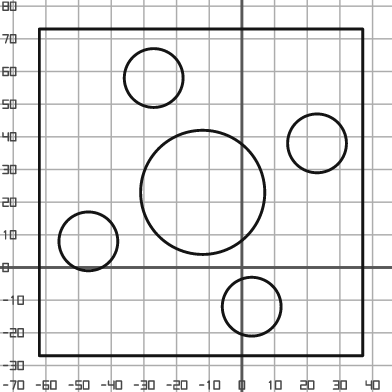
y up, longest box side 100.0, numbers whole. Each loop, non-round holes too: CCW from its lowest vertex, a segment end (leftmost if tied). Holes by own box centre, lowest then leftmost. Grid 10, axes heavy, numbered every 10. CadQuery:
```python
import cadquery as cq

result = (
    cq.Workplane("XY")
    .moveTo(-62.0, -27.0)
    .lineTo(37.0, -27.0)
    .lineTo(37.0, 73.0)
    .lineTo(-62.0, 73.0)
    .close()
    .moveTo(3.0, -12.0)
    .circle(9.0)
    .moveTo(-47.0, 8.0)
    .circle(9.0)
    .moveTo(-12.0, 23.0)
    .circle(19.0)
    .moveTo(23.0, 38.0)
    .circle(9.0)
    .moveTo(-27.0, 58.0)
    .circle(9.0)
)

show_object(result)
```